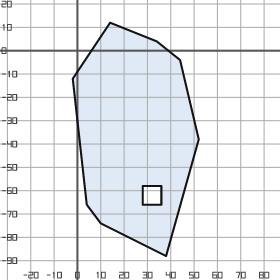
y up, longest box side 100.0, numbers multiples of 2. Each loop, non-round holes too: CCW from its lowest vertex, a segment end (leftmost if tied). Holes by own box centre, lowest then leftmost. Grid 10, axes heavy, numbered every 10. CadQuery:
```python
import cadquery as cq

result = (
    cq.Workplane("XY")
    .moveTo(38.0, -88.0)
    .lineTo(52.0, -38.0)
    .lineTo(44.0, -4.0)
    .lineTo(34.0, 4.0)
    .lineTo(14.0, 12.0)
    .lineTo(-2.0, -12.0)
    .lineTo(4.0, -66.0)
    .lineTo(10.0, -74.0)
    .close()
    .moveTo(28.0, -66.0)
    .lineTo(36.0, -66.0)
    .lineTo(36.0, -58.0)
    .lineTo(28.0, -58.0)
    .close()
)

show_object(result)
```